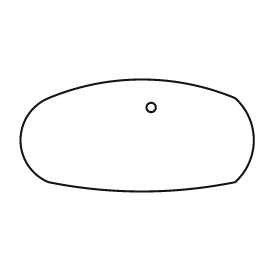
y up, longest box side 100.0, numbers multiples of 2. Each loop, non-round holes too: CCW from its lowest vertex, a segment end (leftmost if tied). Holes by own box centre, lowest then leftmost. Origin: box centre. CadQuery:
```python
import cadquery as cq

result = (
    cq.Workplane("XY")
    .moveTo(-38.0, -20.0)
    .threePointArc((2.0, -24.0), (42.0, -20.0))
    .threePointArc((50.0, -2.0), (42.0, 16.0))
    .threePointArc((2.0, 24.0), (-38.0, 16.0))
    .threePointArc((-50.0, -2.0), (-38.0, -20.0))
    .close()
    .moveTo(6.0, 12.0)
    .circle(2.0)
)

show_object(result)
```